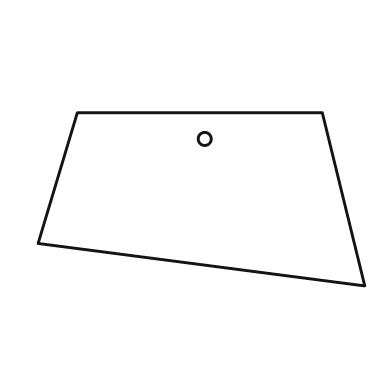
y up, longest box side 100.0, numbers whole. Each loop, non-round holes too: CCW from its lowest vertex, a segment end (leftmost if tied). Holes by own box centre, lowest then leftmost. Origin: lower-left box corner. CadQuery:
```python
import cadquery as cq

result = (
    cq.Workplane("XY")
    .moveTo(100.0, 0.0)
    .lineTo(87.0, 53.0)
    .lineTo(12.0, 53.0)
    .lineTo(0.0, 13.0)
    .close()
    .moveTo(51.0, 45.0)
    .circle(2.0)
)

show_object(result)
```